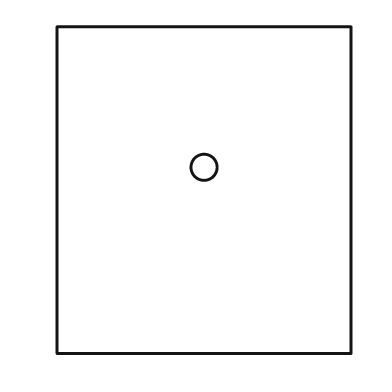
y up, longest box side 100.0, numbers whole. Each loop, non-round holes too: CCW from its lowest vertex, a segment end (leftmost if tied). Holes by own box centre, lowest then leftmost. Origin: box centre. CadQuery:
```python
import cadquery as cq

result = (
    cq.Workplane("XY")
    .moveTo(-45.0, -50.0)
    .lineTo(45.0, -50.0)
    .lineTo(45.0, 50.0)
    .lineTo(-45.0, 50.0)
    .close()
    .moveTo(0.0, 7.0)
    .circle(4.0)
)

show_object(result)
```